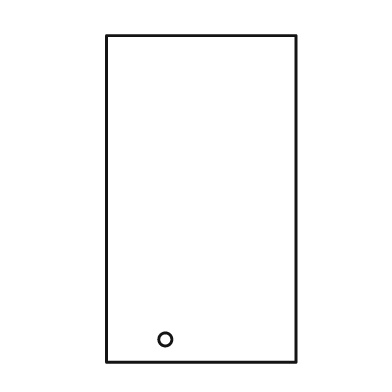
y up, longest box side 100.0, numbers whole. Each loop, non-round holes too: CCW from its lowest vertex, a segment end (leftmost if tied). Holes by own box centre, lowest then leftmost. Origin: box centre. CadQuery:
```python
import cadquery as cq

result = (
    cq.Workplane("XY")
    .moveTo(-29.0, -50.0)
    .lineTo(29.0, -50.0)
    .lineTo(29.0, 50.0)
    .lineTo(-29.0, 50.0)
    .close()
    .moveTo(-11.0, -43.0)
    .circle(2.0)
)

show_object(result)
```